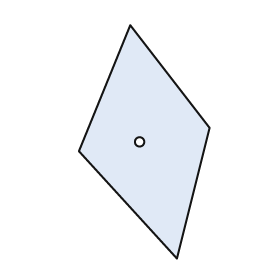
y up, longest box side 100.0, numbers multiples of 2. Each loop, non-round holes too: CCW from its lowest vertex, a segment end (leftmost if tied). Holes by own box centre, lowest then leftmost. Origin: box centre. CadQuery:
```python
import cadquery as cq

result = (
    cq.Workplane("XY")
    .moveTo(14.0, -50.0)
    .lineTo(28.0, 6.0)
    .lineTo(-6.0, 50.0)
    .lineTo(-28.0, -4.0)
    .close()
    .moveTo(-2.0, 0.0)
    .circle(2.0)
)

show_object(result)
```